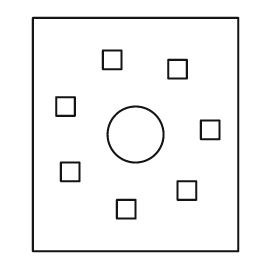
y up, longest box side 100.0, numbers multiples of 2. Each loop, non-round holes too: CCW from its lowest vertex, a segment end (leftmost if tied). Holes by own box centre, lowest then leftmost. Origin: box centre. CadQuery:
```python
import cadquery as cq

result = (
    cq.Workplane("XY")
    .moveTo(-44.0, -50.0)
    .lineTo(44.0, -50.0)
    .lineTo(44.0, 50.0)
    .lineTo(-44.0, 50.0)
    .close()
    .moveTo(-8.0, -36.0)
    .lineTo(0.0, -36.0)
    .lineTo(0.0, -28.0)
    .lineTo(-8.0, -28.0)
    .close()
    .moveTo(18.0, -28.0)
    .lineTo(26.0, -28.0)
    .lineTo(26.0, -20.0)
    .lineTo(18.0, -20.0)
    .close()
    .moveTo(-32.0, -20.0)
    .lineTo(-24.0, -20.0)
    .lineTo(-24.0, -12.0)
    .lineTo(-32.0, -12.0)
    .close()
    .moveTo(0.0, 0.0)
    .circle(12.0)
    .moveTo(28.0, -2.0)
    .lineTo(36.0, -2.0)
    .lineTo(36.0, 6.0)
    .lineTo(28.0, 6.0)
    .close()
    .moveTo(-34.0, 8.0)
    .lineTo(-26.0, 8.0)
    .lineTo(-26.0, 16.0)
    .lineTo(-34.0, 16.0)
    .close()
    .moveTo(14.0, 24.0)
    .lineTo(22.0, 24.0)
    .lineTo(22.0, 32.0)
    .lineTo(14.0, 32.0)
    .close()
    .moveTo(-14.0, 28.0)
    .lineTo(-6.0, 28.0)
    .lineTo(-6.0, 36.0)
    .lineTo(-14.0, 36.0)
    .close()
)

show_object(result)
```